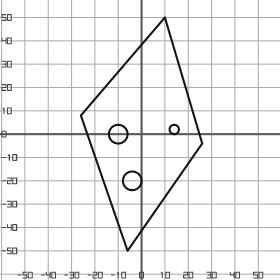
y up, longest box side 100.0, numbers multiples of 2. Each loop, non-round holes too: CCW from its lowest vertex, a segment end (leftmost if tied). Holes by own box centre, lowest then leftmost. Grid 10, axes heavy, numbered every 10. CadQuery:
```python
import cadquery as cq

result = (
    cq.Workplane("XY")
    .moveTo(-6.0, -50.0)
    .lineTo(26.0, -4.0)
    .lineTo(10.0, 50.0)
    .lineTo(-26.0, 8.0)
    .close()
    .moveTo(-4.0, -20.0)
    .circle(4.0)
    .moveTo(-10.0, 0.0)
    .circle(4.0)
    .moveTo(14.0, 2.0)
    .circle(2.0)
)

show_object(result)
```